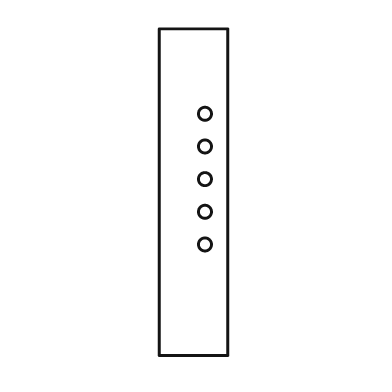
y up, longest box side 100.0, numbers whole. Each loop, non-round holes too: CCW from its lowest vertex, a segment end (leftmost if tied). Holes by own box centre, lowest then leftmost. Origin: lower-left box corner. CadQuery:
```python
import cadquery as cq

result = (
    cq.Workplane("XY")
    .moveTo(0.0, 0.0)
    .lineTo(21.0, 0.0)
    .lineTo(21.0, 100.0)
    .lineTo(0.0, 100.0)
    .close()
    .moveTo(14.0, 34.0)
    .circle(2.0)
    .moveTo(14.0, 44.0)
    .circle(2.0)
    .moveTo(14.0, 54.0)
    .circle(2.0)
    .moveTo(14.0, 64.0)
    .circle(2.0)
    .moveTo(14.0, 74.0)
    .circle(2.0)
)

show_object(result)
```